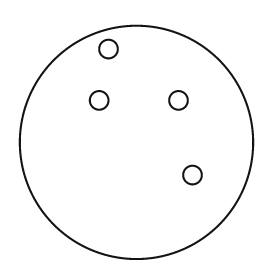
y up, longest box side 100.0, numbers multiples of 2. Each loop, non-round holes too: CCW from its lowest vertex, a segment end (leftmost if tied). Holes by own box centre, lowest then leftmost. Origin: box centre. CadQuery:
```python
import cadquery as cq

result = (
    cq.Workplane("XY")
    .moveTo(0.0, 0.0)
    .circle(50.0)
    .moveTo(24.0, -14.0)
    .circle(4.0)
    .moveTo(-16.0, 18.0)
    .circle(4.0)
    .moveTo(18.0, 18.0)
    .circle(4.0)
    .moveTo(-12.0, 40.0)
    .circle(4.0)
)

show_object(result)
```